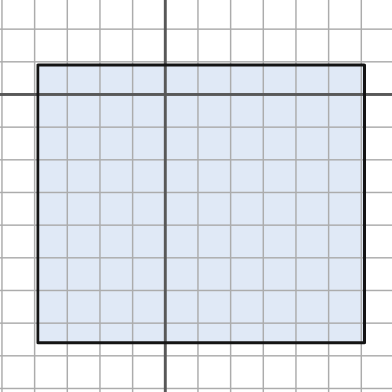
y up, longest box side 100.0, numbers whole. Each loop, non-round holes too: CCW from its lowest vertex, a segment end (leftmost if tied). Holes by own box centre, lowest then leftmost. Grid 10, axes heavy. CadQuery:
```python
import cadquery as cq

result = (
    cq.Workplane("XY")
    .moveTo(-39.0, -76.0)
    .lineTo(61.0, -76.0)
    .lineTo(61.0, 9.0)
    .lineTo(-39.0, 9.0)
    .close()
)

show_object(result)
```